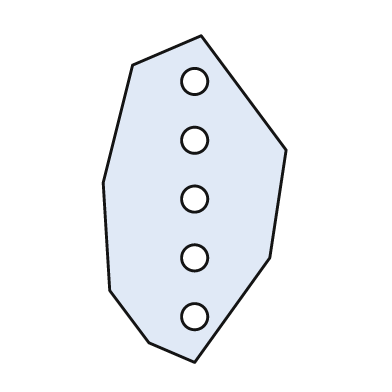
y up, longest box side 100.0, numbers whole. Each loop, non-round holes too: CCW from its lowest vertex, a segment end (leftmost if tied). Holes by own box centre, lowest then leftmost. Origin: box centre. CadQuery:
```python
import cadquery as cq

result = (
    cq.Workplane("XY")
    .moveTo(0.0, -50.0)
    .lineTo(23.0, -18.0)
    .lineTo(28.0, 15.0)
    .lineTo(2.0, 50.0)
    .lineTo(-19.0, 41.0)
    .lineTo(-28.0, 5.0)
    .lineTo(-26.0, -28.0)
    .lineTo(-14.0, -44.0)
    .close()
    .moveTo(0.0, -36.0)
    .circle(4.0)
    .moveTo(0.0, -18.0)
    .circle(4.0)
    .moveTo(0.0, 0.0)
    .circle(4.0)
    .moveTo(0.0, 18.0)
    .circle(4.0)
    .moveTo(0.0, 36.0)
    .circle(4.0)
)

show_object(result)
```